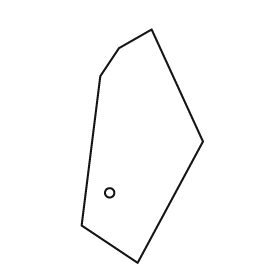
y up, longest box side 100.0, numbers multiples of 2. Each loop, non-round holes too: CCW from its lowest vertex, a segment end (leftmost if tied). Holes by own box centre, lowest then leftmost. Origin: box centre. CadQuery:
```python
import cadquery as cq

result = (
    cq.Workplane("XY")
    .moveTo(-2.0, -50.0)
    .lineTo(26.0, 2.0)
    .lineTo(4.0, 50.0)
    .lineTo(-10.0, 42.0)
    .lineTo(-18.0, 30.0)
    .lineTo(-26.0, -34.0)
    .close()
    .moveTo(-14.0, -20.0)
    .circle(2.0)
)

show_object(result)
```